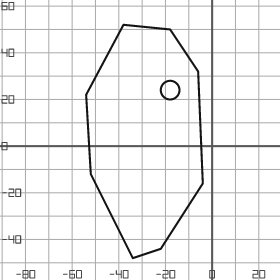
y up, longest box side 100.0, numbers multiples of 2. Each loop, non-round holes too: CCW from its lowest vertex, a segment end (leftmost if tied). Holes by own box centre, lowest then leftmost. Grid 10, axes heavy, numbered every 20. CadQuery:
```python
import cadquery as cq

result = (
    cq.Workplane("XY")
    .moveTo(-34.0, -48.0)
    .lineTo(-22.0, -44.0)
    .lineTo(-4.0, -16.0)
    .lineTo(-6.0, 32.0)
    .lineTo(-18.0, 50.0)
    .lineTo(-38.0, 52.0)
    .lineTo(-54.0, 22.0)
    .lineTo(-52.0, -12.0)
    .close()
    .moveTo(-18.0, 24.0)
    .circle(4.0)
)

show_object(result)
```